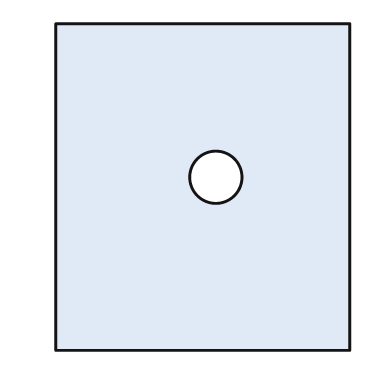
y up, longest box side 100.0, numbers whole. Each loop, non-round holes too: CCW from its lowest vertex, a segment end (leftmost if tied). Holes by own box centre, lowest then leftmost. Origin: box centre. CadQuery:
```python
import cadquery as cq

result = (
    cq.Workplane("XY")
    .moveTo(-45.0, -50.0)
    .lineTo(45.0, -50.0)
    .lineTo(45.0, 50.0)
    .lineTo(-45.0, 50.0)
    .close()
    .moveTo(4.0, 3.0)
    .circle(8.0)
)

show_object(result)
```